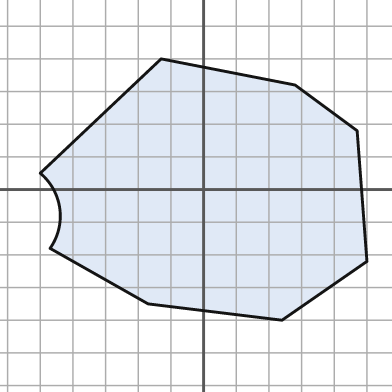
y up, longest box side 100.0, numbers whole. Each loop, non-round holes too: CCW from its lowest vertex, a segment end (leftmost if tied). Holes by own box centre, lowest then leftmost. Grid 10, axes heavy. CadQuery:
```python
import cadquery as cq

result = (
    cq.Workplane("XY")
    .moveTo(24.0, -40.0)
    .lineTo(50.0, -22.0)
    .lineTo(47.0, 18.0)
    .lineTo(28.0, 32.0)
    .lineTo(-13.0, 40.0)
    .lineTo(-50.0, 5.0)
    .threePointArc((-44.0, -6.0), (-47.0, -18.0))
    .lineTo(-17.0, -35.0)
    .close()
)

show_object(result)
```